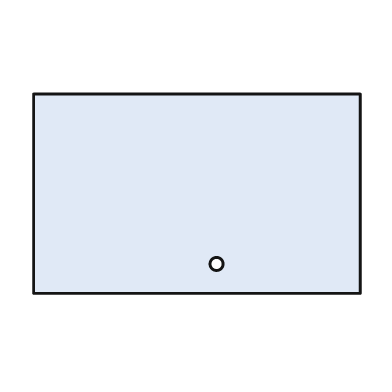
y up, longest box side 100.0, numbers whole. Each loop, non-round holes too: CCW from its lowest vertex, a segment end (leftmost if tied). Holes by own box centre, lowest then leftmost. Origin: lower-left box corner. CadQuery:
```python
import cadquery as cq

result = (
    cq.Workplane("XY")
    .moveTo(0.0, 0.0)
    .lineTo(100.0, 0.0)
    .lineTo(100.0, 61.0)
    .lineTo(0.0, 61.0)
    .close()
    .moveTo(56.0, 9.0)
    .circle(2.0)
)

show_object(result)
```